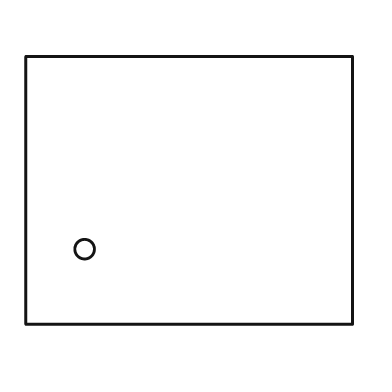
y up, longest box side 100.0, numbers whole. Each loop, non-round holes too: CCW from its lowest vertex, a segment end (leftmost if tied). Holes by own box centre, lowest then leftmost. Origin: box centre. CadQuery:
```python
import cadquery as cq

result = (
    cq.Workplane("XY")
    .moveTo(-50.0, -41.0)
    .lineTo(50.0, -41.0)
    .lineTo(50.0, 41.0)
    .lineTo(-50.0, 41.0)
    .close()
    .moveTo(-32.0, -18.0)
    .circle(3.0)
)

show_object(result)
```